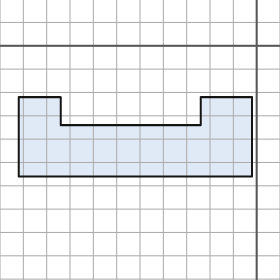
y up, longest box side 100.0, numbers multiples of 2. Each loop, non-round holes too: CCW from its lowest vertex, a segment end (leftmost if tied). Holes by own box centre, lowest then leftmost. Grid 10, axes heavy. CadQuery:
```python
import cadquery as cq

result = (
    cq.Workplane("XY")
    .moveTo(-102.0, -56.0)
    .lineTo(-2.0, -56.0)
    .lineTo(-2.0, -22.0)
    .lineTo(-24.0, -22.0)
    .lineTo(-24.0, -34.0)
    .lineTo(-84.0, -34.0)
    .lineTo(-84.0, -22.0)
    .lineTo(-102.0, -22.0)
    .close()
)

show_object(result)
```